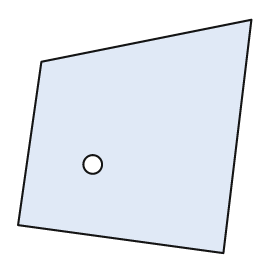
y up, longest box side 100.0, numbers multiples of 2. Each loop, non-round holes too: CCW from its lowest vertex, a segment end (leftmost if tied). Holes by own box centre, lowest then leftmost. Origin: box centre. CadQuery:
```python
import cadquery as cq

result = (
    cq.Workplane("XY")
    .moveTo(38.0, -50.0)
    .lineTo(50.0, 50.0)
    .lineTo(-40.0, 32.0)
    .lineTo(-50.0, -38.0)
    .close()
    .moveTo(-18.0, -12.0)
    .circle(4.0)
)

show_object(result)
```